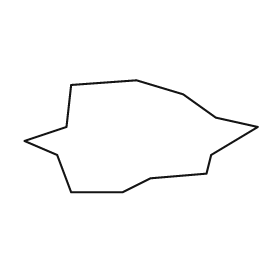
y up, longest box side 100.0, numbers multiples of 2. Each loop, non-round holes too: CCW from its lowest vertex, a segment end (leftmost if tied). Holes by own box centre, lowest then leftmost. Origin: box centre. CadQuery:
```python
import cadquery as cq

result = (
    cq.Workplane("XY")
    .moveTo(-30.0, -24.0)
    .lineTo(-8.0, -24.0)
    .lineTo(4.0, -18.0)
    .lineTo(28.0, -16.0)
    .lineTo(30.0, -8.0)
    .lineTo(50.0, 4.0)
    .lineTo(32.0, 8.0)
    .lineTo(18.0, 18.0)
    .lineTo(-2.0, 24.0)
    .lineTo(-30.0, 22.0)
    .lineTo(-32.0, 4.0)
    .lineTo(-50.0, -2.0)
    .lineTo(-36.0, -8.0)
    .close()
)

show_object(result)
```